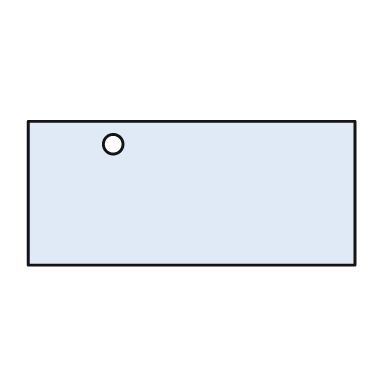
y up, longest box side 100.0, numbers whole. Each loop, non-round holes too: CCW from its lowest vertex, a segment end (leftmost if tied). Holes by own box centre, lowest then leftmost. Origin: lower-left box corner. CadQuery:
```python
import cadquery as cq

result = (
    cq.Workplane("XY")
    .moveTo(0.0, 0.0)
    .lineTo(100.0, 0.0)
    .lineTo(100.0, 44.0)
    .lineTo(0.0, 44.0)
    .close()
    .moveTo(26.0, 37.0)
    .circle(3.0)
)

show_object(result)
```